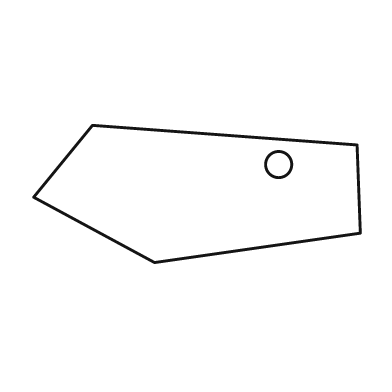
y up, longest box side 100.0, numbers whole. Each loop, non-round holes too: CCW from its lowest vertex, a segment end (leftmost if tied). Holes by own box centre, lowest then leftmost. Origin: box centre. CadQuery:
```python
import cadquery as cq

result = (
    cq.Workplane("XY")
    .moveTo(-13.0, -21.0)
    .lineTo(50.0, -12.0)
    .lineTo(49.0, 15.0)
    .lineTo(-32.0, 21.0)
    .lineTo(-50.0, -1.0)
    .close()
    .moveTo(25.0, 9.0)
    .circle(4.0)
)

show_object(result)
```